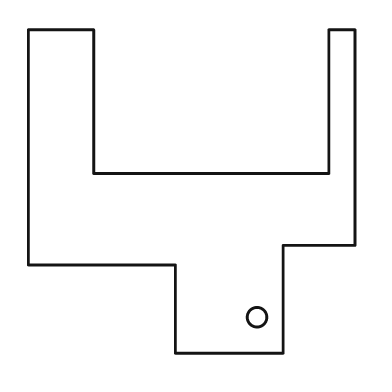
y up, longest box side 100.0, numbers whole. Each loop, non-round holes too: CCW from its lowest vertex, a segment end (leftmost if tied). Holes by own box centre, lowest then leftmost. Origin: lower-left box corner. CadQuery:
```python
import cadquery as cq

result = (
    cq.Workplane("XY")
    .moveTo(45.0, 0.0)
    .lineTo(78.0, 0.0)
    .lineTo(78.0, 33.0)
    .lineTo(100.0, 33.0)
    .lineTo(100.0, 99.0)
    .lineTo(92.0, 99.0)
    .lineTo(92.0, 55.0)
    .lineTo(20.0, 55.0)
    .lineTo(20.0, 99.0)
    .lineTo(0.0, 99.0)
    .lineTo(0.0, 27.0)
    .lineTo(45.0, 27.0)
    .close()
    .moveTo(70.0, 11.0)
    .circle(3.0)
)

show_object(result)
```